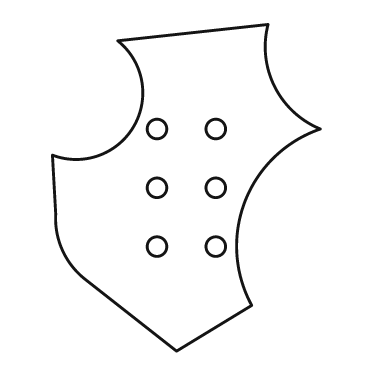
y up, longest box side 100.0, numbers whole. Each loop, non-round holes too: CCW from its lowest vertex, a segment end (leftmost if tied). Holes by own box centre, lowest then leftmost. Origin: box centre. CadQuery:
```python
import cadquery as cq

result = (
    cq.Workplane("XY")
    .moveTo(-3.0, -50.0)
    .lineTo(20.0, -36.0)
    .threePointArc((18.0, -4.0), (41.0, 18.0))
    .threePointArc((27.0, 31.0), (25.0, 50.0))
    .lineTo(-21.0, 45.0)
    .threePointArc((-16.0, 19.0), (-41.0, 10.0))
    .lineTo(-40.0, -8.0)
    .threePointArc((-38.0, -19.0), (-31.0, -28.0))
    .close()
    .moveTo(-9.0, -18.0)
    .circle(3.0)
    .moveTo(9.0, -18.0)
    .circle(3.0)
    .moveTo(-9.0, 0.0)
    .circle(3.0)
    .moveTo(9.0, 0.0)
    .circle(3.0)
    .moveTo(-9.0, 18.0)
    .circle(3.0)
    .moveTo(9.0, 18.0)
    .circle(3.0)
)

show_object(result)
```